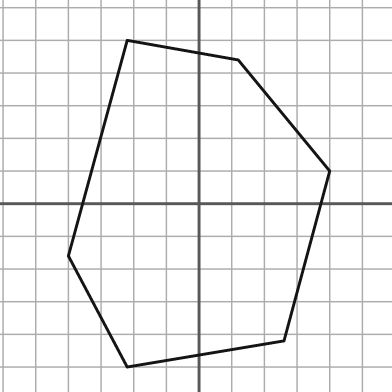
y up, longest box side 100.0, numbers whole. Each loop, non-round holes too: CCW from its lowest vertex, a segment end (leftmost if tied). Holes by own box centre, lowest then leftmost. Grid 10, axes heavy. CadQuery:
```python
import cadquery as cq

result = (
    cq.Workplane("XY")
    .moveTo(-22.0, -50.0)
    .lineTo(26.0, -42.0)
    .lineTo(40.0, 10.0)
    .lineTo(12.0, 44.0)
    .lineTo(-22.0, 50.0)
    .lineTo(-40.0, -16.0)
    .close()
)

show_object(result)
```